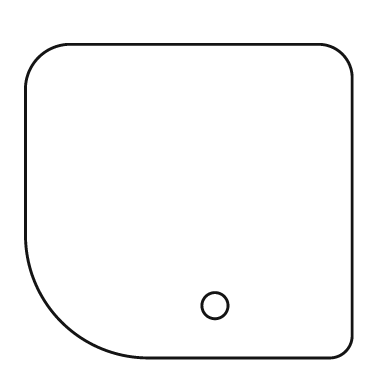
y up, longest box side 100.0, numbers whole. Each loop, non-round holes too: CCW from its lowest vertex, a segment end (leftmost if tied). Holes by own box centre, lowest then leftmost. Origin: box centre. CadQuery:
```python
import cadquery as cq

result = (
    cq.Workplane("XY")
    .moveTo(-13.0, -48.0)
    .lineTo(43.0, -48.0)
    .threePointArc((48.0, -46.0), (50.0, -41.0))
    .lineTo(50.0, 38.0)
    .threePointArc((47.0, 45.0), (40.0, 48.0))
    .lineTo(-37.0, 48.0)
    .threePointArc((-46.0, 44.0), (-50.0, 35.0))
    .lineTo(-50.0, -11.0)
    .threePointArc((-39.0, -37.0), (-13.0, -48.0))
    .close()
    .moveTo(8.0, -32.0)
    .circle(4.0)
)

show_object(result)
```